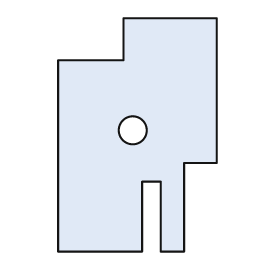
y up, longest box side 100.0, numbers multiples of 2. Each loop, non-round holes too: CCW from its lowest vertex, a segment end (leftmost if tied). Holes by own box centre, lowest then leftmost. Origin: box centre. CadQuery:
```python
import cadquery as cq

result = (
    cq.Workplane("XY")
    .moveTo(-34.0, -50.0)
    .lineTo(2.0, -50.0)
    .lineTo(2.0, -20.0)
    .lineTo(10.0, -20.0)
    .lineTo(10.0, -50.0)
    .lineTo(20.0, -50.0)
    .lineTo(20.0, -12.0)
    .lineTo(34.0, -12.0)
    .lineTo(34.0, 50.0)
    .lineTo(-6.0, 50.0)
    .lineTo(-6.0, 32.0)
    .lineTo(-34.0, 32.0)
    .close()
    .moveTo(-2.0, 2.0)
    .circle(6.0)
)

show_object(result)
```